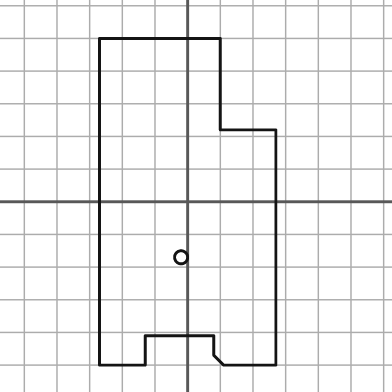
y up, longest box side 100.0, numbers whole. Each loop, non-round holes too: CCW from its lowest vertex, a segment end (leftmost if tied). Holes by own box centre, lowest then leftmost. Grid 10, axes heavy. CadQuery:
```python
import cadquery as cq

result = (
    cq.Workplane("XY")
    .moveTo(-27.0, -50.0)
    .lineTo(-13.0, -50.0)
    .lineTo(-13.0, -41.0)
    .lineTo(8.0, -41.0)
    .lineTo(8.0, -47.0)
    .lineTo(11.0, -50.0)
    .lineTo(27.0, -50.0)
    .lineTo(27.0, 22.0)
    .lineTo(10.0, 22.0)
    .lineTo(10.0, 50.0)
    .lineTo(-27.0, 50.0)
    .close()
    .moveTo(-2.0, -17.0)
    .circle(2.0)
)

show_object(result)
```